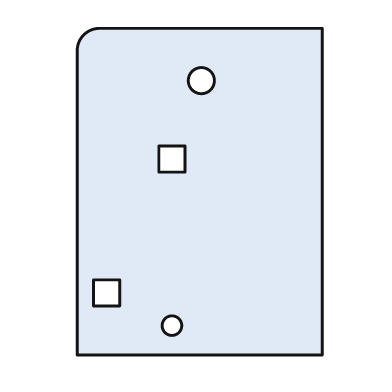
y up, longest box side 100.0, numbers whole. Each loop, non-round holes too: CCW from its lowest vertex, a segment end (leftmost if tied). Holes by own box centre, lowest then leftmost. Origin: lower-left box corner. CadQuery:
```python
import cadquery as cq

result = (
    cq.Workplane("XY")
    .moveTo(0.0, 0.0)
    .lineTo(75.0, 0.0)
    .lineTo(75.0, 100.0)
    .lineTo(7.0, 100.0)
    .threePointArc((2.0, 98.0), (0.0, 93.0))
    .close()
    .moveTo(29.0, 9.0)
    .circle(3.0)
    .moveTo(5.0, 15.0)
    .lineTo(13.0, 15.0)
    .lineTo(13.0, 23.0)
    .lineTo(5.0, 23.0)
    .close()
    .moveTo(25.0, 56.0)
    .lineTo(33.0, 56.0)
    .lineTo(33.0, 64.0)
    .lineTo(25.0, 64.0)
    .close()
    .moveTo(38.0, 84.0)
    .circle(4.0)
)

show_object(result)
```